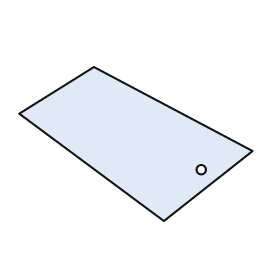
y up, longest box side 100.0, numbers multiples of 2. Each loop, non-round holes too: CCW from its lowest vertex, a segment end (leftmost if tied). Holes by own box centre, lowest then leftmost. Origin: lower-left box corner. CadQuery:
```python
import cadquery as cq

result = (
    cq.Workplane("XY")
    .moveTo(62.0, 0.0)
    .lineTo(100.0, 30.0)
    .lineTo(32.0, 66.0)
    .lineTo(0.0, 46.0)
    .close()
    .moveTo(78.0, 22.0)
    .circle(2.0)
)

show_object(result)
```